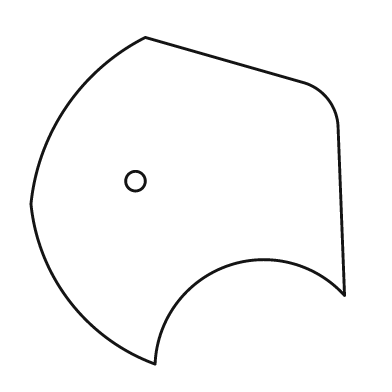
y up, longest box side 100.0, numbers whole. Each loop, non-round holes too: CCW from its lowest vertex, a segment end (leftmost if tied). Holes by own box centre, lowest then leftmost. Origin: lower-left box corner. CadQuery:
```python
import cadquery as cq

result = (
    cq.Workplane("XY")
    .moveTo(38.0, 0.0)
    .threePointArc((60.0, 30.0), (96.0, 21.0))
    .lineTo(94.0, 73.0)
    .threePointArc((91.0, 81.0), (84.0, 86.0))
    .lineTo(35.0, 100.0)
    .threePointArc((11.0, 79.0), (0.0, 49.0))
    .threePointArc((12.0, 19.0), (38.0, 0.0))
    .close()
    .moveTo(32.0, 56.0)
    .circle(3.0)
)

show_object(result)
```